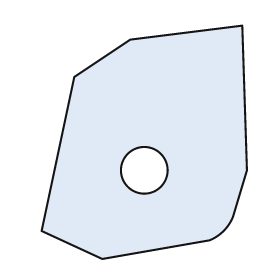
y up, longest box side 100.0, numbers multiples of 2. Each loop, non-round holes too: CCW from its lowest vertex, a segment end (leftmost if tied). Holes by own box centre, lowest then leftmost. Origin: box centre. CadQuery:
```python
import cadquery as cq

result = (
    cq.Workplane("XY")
    .moveTo(-18.0, -50.0)
    .lineTo(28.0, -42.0)
    .threePointArc((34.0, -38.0), (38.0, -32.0))
    .lineTo(44.0, -12.0)
    .lineTo(42.0, 50.0)
    .lineTo(-6.0, 44.0)
    .lineTo(-30.0, 28.0)
    .lineTo(-44.0, -38.0)
    .close()
    .moveTo(0.0, -12.0)
    .circle(10.0)
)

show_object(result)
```